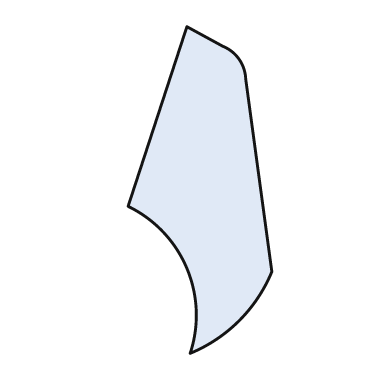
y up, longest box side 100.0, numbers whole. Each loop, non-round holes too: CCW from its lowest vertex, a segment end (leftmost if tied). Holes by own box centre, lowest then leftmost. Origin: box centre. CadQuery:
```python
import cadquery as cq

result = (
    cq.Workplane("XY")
    .moveTo(-3.0, -50.0)
    .threePointArc((12.0, -40.0), (22.0, -25.0))
    .lineTo(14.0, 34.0)
    .threePointArc((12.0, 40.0), (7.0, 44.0))
    .lineTo(-4.0, 50.0)
    .lineTo(-22.0, -5.0)
    .threePointArc((-4.0, -24.0), (-3.0, -50.0))
    .close()
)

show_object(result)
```